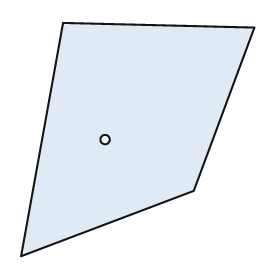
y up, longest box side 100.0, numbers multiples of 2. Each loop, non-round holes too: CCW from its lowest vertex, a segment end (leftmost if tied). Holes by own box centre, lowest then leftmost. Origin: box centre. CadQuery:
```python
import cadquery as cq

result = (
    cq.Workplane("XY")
    .moveTo(-50.0, -50.0)
    .lineTo(24.0, -22.0)
    .lineTo(50.0, 48.0)
    .lineTo(-32.0, 50.0)
    .close()
    .moveTo(-14.0, 0.0)
    .circle(2.0)
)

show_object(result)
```